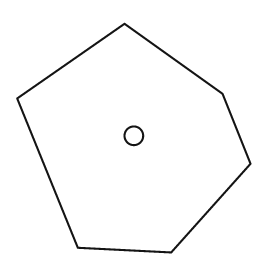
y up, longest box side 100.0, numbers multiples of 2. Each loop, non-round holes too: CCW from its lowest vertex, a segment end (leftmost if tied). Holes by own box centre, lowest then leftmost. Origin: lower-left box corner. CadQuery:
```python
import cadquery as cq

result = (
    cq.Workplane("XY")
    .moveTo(66.0, 0.0)
    .lineTo(100.0, 38.0)
    .lineTo(88.0, 68.0)
    .lineTo(46.0, 98.0)
    .lineTo(0.0, 66.0)
    .lineTo(26.0, 2.0)
    .close()
    .moveTo(50.0, 50.0)
    .circle(4.0)
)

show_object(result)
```